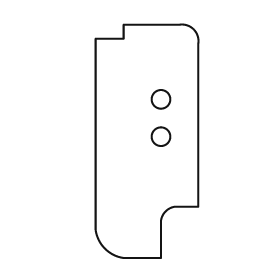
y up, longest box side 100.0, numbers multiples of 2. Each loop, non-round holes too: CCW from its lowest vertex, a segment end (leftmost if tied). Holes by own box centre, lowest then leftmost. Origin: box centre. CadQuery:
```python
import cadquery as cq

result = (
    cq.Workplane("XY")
    .moveTo(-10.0, -50.0)
    .lineTo(6.0, -50.0)
    .lineTo(6.0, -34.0)
    .threePointArc((8.0, -30.0), (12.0, -28.0))
    .lineTo(22.0, -28.0)
    .lineTo(22.0, 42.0)
    .threePointArc((20.0, 48.0), (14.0, 50.0))
    .lineTo(-10.0, 50.0)
    .lineTo(-10.0, 44.0)
    .lineTo(-22.0, 44.0)
    .lineTo(-22.0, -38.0)
    .threePointArc((-18.0, -46.0), (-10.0, -50.0))
    .close()
    .moveTo(6.0, 2.0)
    .circle(4.0)
    .moveTo(6.0, 18.0)
    .circle(4.0)
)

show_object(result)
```